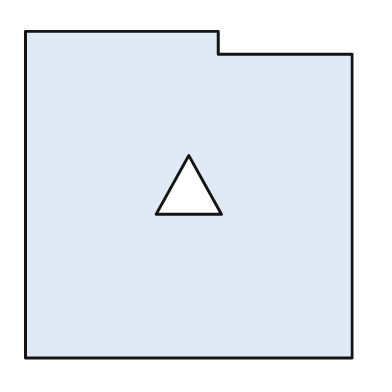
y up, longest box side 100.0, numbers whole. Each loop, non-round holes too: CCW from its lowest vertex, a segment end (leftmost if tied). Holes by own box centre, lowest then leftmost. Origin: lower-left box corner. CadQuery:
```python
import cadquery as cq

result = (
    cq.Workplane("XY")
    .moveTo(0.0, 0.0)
    .lineTo(100.0, 0.0)
    .lineTo(100.0, 93.0)
    .lineTo(59.0, 93.0)
    .lineTo(59.0, 100.0)
    .lineTo(0.0, 100.0)
    .close()
    .moveTo(40.0, 44.0)
    .lineTo(60.0, 44.0)
    .lineTo(50.0, 62.0)
    .close()
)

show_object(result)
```